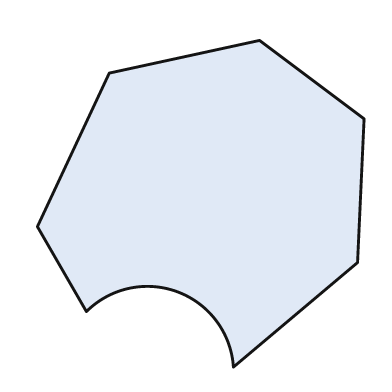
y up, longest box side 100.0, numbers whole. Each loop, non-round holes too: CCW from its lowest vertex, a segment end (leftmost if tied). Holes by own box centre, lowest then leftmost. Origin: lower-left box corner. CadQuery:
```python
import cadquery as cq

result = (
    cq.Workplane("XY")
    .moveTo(60.0, 0.0)
    .lineTo(98.0, 32.0)
    .lineTo(100.0, 76.0)
    .lineTo(68.0, 100.0)
    .lineTo(22.0, 90.0)
    .lineTo(0.0, 43.0)
    .lineTo(15.0, 17.0)
    .threePointArc((43.0, 23.0), (60.0, 0.0))
    .close()
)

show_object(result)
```